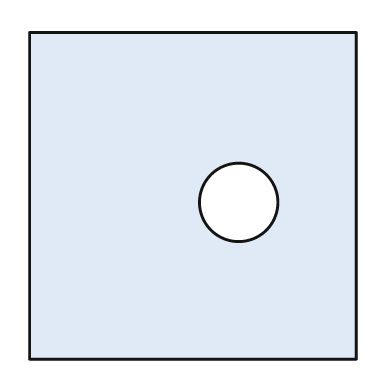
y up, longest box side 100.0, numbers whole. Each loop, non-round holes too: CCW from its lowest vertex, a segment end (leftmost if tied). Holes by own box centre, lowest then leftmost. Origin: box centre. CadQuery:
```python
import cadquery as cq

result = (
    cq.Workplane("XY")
    .moveTo(-50.0, -50.0)
    .lineTo(50.0, -50.0)
    .lineTo(50.0, 50.0)
    .lineTo(-50.0, 50.0)
    .close()
    .moveTo(14.0, -2.0)
    .circle(12.0)
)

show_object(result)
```